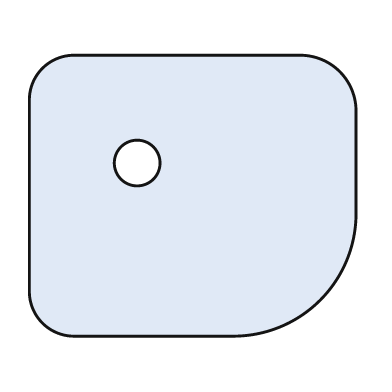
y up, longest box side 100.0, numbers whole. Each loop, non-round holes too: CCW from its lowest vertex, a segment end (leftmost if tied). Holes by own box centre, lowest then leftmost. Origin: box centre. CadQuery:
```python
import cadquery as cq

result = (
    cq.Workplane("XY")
    .moveTo(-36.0, -43.0)
    .lineTo(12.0, -43.0)
    .threePointArc((39.0, -32.0), (50.0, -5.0))
    .lineTo(50.0, 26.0)
    .threePointArc((45.0, 38.0), (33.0, 43.0))
    .lineTo(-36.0, 43.0)
    .threePointArc((-46.0, 39.0), (-50.0, 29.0))
    .lineTo(-50.0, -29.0)
    .threePointArc((-46.0, -39.0), (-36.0, -43.0))
    .close()
    .moveTo(-17.0, 10.0)
    .circle(7.0)
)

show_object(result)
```